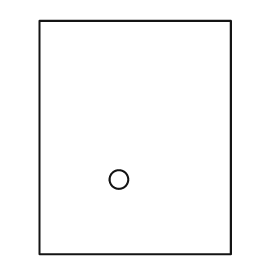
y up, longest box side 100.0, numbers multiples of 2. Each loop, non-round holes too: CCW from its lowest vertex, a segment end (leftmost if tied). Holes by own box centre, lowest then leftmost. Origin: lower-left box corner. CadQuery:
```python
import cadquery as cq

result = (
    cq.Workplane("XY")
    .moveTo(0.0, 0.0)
    .lineTo(82.0, 0.0)
    .lineTo(82.0, 100.0)
    .lineTo(0.0, 100.0)
    .close()
    .moveTo(34.0, 32.0)
    .circle(4.0)
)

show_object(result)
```